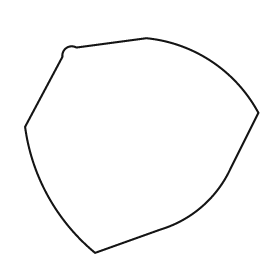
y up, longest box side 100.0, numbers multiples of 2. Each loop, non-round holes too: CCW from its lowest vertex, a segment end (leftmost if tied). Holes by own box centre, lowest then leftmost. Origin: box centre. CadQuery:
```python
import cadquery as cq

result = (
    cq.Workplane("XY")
    .moveTo(-20.0, -46.0)
    .lineTo(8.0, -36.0)
    .threePointArc((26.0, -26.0), (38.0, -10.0))
    .lineTo(50.0, 14.0)
    .threePointArc((30.0, 36.0), (2.0, 46.0))
    .lineTo(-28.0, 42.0)
    .threePointArc((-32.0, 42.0), (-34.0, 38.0))
    .lineTo(-50.0, 8.0)
    .threePointArc((-40.0, -22.0), (-20.0, -46.0))
    .close()
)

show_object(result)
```